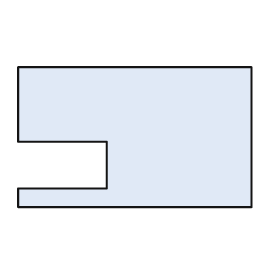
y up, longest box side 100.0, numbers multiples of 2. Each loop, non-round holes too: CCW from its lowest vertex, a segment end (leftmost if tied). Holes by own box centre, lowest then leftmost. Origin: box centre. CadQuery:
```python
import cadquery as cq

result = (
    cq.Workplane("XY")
    .moveTo(-50.0, -30.0)
    .lineTo(50.0, -30.0)
    .lineTo(50.0, 30.0)
    .lineTo(-50.0, 30.0)
    .lineTo(-50.0, -2.0)
    .lineTo(-12.0, -2.0)
    .lineTo(-12.0, -22.0)
    .lineTo(-50.0, -22.0)
    .close()
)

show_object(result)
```